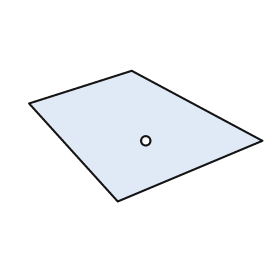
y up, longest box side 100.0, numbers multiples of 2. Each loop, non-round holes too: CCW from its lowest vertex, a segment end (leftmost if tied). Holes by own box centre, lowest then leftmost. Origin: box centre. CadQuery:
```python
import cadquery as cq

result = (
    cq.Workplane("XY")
    .moveTo(-12.0, -28.0)
    .lineTo(50.0, -2.0)
    .lineTo(-6.0, 28.0)
    .lineTo(-50.0, 14.0)
    .close()
    .moveTo(0.0, -2.0)
    .circle(2.0)
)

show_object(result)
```